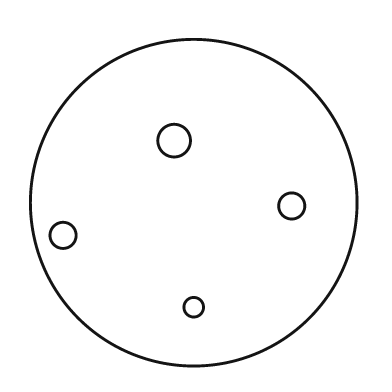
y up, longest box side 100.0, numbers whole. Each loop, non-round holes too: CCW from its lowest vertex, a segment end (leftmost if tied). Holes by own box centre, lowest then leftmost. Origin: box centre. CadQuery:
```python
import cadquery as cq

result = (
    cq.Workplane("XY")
    .moveTo(0.0, 0.0)
    .circle(50.0)
    .moveTo(0.0, -32.0)
    .circle(3.0)
    .moveTo(-40.0, -10.0)
    .circle(4.0)
    .moveTo(30.0, -1.0)
    .circle(4.0)
    .moveTo(-6.0, 19.0)
    .circle(5.0)
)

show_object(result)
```